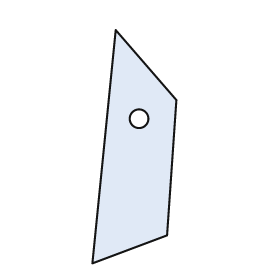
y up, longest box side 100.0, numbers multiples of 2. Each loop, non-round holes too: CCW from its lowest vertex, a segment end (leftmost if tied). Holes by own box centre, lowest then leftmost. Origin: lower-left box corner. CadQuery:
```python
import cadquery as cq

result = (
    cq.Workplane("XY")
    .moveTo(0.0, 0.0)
    .lineTo(32.0, 12.0)
    .lineTo(36.0, 70.0)
    .lineTo(10.0, 100.0)
    .close()
    .moveTo(20.0, 62.0)
    .circle(4.0)
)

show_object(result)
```